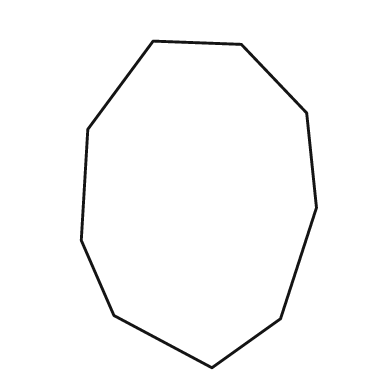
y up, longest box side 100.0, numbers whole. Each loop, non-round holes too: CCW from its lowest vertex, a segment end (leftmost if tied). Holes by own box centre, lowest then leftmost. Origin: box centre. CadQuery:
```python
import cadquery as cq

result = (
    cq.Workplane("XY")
    .moveTo(4.0, -50.0)
    .lineTo(25.0, -35.0)
    .lineTo(36.0, -1.0)
    .lineTo(33.0, 28.0)
    .lineTo(13.0, 49.0)
    .lineTo(-14.0, 50.0)
    .lineTo(-34.0, 23.0)
    .lineTo(-36.0, -11.0)
    .lineTo(-26.0, -34.0)
    .close()
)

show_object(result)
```